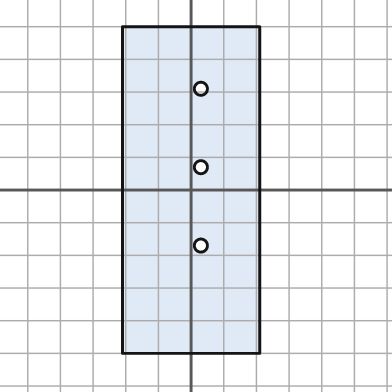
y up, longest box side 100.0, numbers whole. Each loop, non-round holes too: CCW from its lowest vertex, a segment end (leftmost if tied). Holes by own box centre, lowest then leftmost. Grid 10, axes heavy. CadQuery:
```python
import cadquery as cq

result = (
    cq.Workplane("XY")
    .moveTo(-21.0, -50.0)
    .lineTo(21.0, -50.0)
    .lineTo(21.0, 50.0)
    .lineTo(-21.0, 50.0)
    .close()
    .moveTo(3.0, -17.0)
    .circle(2.0)
    .moveTo(3.0, 7.0)
    .circle(2.0)
    .moveTo(3.0, 31.0)
    .circle(2.0)
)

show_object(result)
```